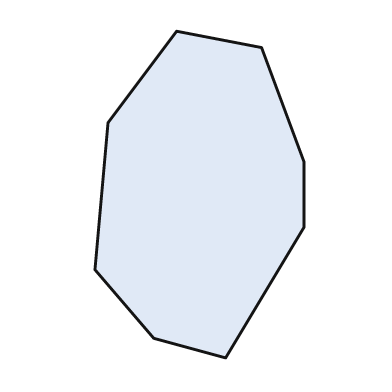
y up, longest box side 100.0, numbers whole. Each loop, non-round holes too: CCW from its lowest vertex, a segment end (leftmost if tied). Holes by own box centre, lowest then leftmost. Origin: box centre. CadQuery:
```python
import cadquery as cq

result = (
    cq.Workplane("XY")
    .moveTo(8.0, -50.0)
    .lineTo(32.0, -10.0)
    .lineTo(32.0, 10.0)
    .lineTo(19.0, 45.0)
    .lineTo(-7.0, 50.0)
    .lineTo(-28.0, 22.0)
    .lineTo(-32.0, -23.0)
    .lineTo(-14.0, -44.0)
    .close()
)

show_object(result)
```